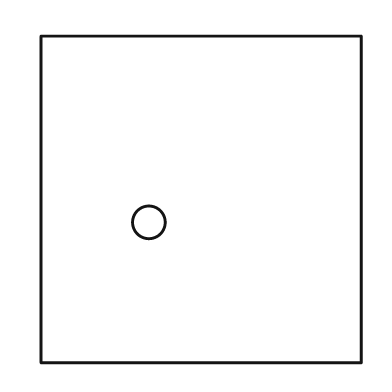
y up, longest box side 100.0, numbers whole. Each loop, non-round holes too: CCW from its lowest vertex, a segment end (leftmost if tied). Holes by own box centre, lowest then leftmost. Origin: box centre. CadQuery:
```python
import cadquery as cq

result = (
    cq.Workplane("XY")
    .moveTo(-49.0, -50.0)
    .lineTo(49.0, -50.0)
    .lineTo(49.0, 50.0)
    .lineTo(-49.0, 50.0)
    .close()
    .moveTo(-16.0, -7.0)
    .circle(5.0)
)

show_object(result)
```